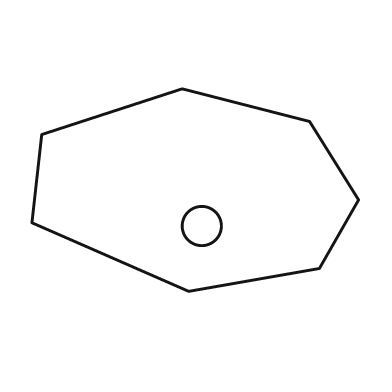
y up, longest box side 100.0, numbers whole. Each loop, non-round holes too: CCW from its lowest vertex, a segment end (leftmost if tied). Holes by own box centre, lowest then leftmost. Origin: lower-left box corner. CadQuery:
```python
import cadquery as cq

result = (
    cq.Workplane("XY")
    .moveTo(48.0, 0.0)
    .lineTo(88.0, 7.0)
    .lineTo(100.0, 28.0)
    .lineTo(85.0, 52.0)
    .lineTo(46.0, 62.0)
    .lineTo(3.0, 48.0)
    .lineTo(0.0, 21.0)
    .close()
    .moveTo(52.0, 20.0)
    .circle(6.0)
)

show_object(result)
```